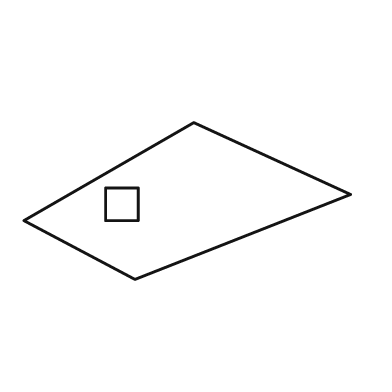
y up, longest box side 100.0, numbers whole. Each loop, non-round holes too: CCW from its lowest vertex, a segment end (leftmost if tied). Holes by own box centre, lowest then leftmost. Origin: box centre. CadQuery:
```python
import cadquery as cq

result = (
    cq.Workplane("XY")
    .moveTo(-16.0, -24.0)
    .lineTo(50.0, 2.0)
    .lineTo(2.0, 24.0)
    .lineTo(-50.0, -6.0)
    .close()
    .moveTo(-25.0, -6.0)
    .lineTo(-15.0, -6.0)
    .lineTo(-15.0, 4.0)
    .lineTo(-25.0, 4.0)
    .close()
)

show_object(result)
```